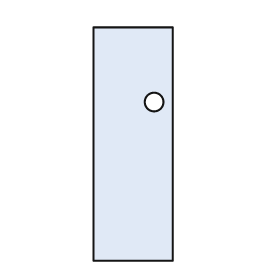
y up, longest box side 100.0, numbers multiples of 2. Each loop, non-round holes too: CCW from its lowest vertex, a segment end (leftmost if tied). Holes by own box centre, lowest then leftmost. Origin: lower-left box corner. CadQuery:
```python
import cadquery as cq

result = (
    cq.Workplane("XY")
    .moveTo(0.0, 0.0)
    .lineTo(34.0, 0.0)
    .lineTo(34.0, 100.0)
    .lineTo(0.0, 100.0)
    .close()
    .moveTo(26.0, 68.0)
    .circle(4.0)
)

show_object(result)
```